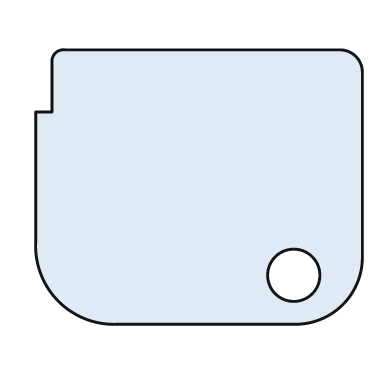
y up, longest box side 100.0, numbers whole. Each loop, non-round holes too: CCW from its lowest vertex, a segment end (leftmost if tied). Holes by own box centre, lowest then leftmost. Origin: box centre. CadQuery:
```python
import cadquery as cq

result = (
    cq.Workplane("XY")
    .moveTo(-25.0, -42.0)
    .lineTo(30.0, -42.0)
    .threePointArc((44.0, -36.0), (50.0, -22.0))
    .lineTo(50.0, 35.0)
    .threePointArc((48.0, 40.0), (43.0, 42.0))
    .lineTo(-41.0, 42.0)
    .threePointArc((-44.0, 41.0), (-45.0, 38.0))
    .lineTo(-45.0, 23.0)
    .lineTo(-50.0, 23.0)
    .lineTo(-50.0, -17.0)
    .threePointArc((-43.0, -35.0), (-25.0, -42.0))
    .close()
    .moveTo(29.0, -27.0)
    .circle(8.0)
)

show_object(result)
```